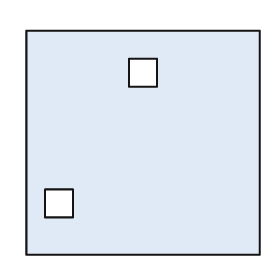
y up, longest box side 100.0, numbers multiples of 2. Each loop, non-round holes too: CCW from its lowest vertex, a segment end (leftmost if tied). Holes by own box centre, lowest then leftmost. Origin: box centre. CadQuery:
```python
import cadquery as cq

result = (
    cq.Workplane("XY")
    .moveTo(-50.0, -48.0)
    .lineTo(50.0, -48.0)
    .lineTo(50.0, 48.0)
    .lineTo(-50.0, 48.0)
    .close()
    .moveTo(-42.0, -32.0)
    .lineTo(-30.0, -32.0)
    .lineTo(-30.0, -20.0)
    .lineTo(-42.0, -20.0)
    .close()
    .moveTo(-6.0, 24.0)
    .lineTo(6.0, 24.0)
    .lineTo(6.0, 36.0)
    .lineTo(-6.0, 36.0)
    .close()
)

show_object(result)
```